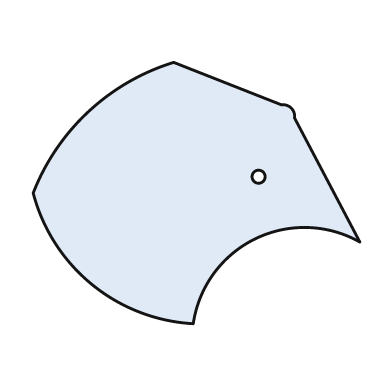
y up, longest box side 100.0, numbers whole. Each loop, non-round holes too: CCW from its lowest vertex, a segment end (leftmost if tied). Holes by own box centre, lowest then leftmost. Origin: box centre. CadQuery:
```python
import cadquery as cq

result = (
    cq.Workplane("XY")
    .moveTo(-1.0, -40.0)
    .threePointArc((18.0, -14.0), (50.0, -15.0))
    .lineTo(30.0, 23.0)
    .threePointArc((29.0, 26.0), (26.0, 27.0))
    .lineTo(-7.0, 40.0)
    .threePointArc((-33.0, 25.0), (-50.0, 0.0))
    .threePointArc((-32.0, -28.0), (-1.0, -40.0))
    .close()
    .moveTo(19.0, 5.0)
    .circle(2.0)
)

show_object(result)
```